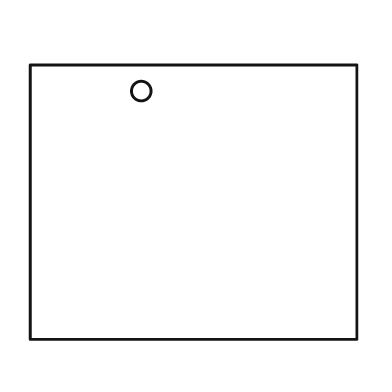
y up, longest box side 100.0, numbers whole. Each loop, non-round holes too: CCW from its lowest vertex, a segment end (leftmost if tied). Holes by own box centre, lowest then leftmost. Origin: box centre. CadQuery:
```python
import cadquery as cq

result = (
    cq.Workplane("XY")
    .moveTo(-50.0, -42.0)
    .lineTo(50.0, -42.0)
    .lineTo(50.0, 42.0)
    .lineTo(-50.0, 42.0)
    .close()
    .moveTo(-16.0, 34.0)
    .circle(3.0)
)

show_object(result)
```